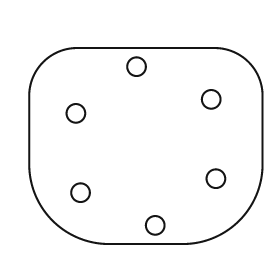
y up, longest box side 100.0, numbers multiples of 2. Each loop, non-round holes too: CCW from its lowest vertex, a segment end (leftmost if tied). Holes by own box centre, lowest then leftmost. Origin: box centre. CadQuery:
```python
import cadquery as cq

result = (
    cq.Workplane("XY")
    .moveTo(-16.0, -42.0)
    .lineTo(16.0, -42.0)
    .threePointArc((40.0, -32.0), (50.0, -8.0))
    .lineTo(50.0, 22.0)
    .threePointArc((44.0, 36.0), (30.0, 42.0))
    .lineTo(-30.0, 42.0)
    .threePointArc((-44.0, 36.0), (-50.0, 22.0))
    .lineTo(-50.0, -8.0)
    .threePointArc((-40.0, -32.0), (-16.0, -42.0))
    .close()
    .moveTo(4.0, -34.0)
    .circle(4.0)
    .moveTo(-28.0, -20.0)
    .circle(4.0)
    .moveTo(30.0, -14.0)
    .circle(4.0)
    .moveTo(-30.0, 14.0)
    .circle(4.0)
    .moveTo(28.0, 20.0)
    .circle(4.0)
    .moveTo(-4.0, 34.0)
    .circle(4.0)
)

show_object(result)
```